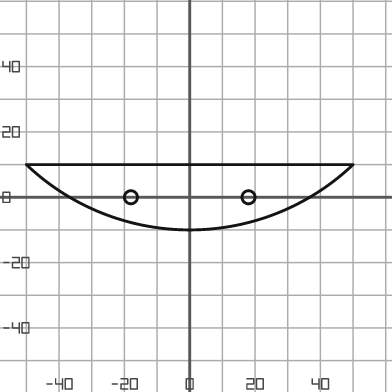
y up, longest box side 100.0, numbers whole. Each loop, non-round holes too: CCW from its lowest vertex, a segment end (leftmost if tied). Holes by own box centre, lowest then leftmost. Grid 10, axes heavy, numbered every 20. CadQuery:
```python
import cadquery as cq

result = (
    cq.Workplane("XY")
    .moveTo(-50.0, 10.0)
    .threePointArc((0.0, -10.0), (50.0, 10.0))
    .close()
    .moveTo(-18.0, 0.0)
    .circle(2.0)
    .moveTo(18.0, 0.0)
    .circle(2.0)
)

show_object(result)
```